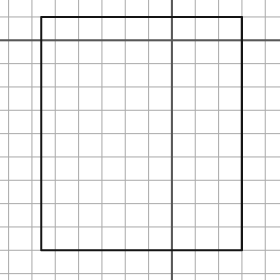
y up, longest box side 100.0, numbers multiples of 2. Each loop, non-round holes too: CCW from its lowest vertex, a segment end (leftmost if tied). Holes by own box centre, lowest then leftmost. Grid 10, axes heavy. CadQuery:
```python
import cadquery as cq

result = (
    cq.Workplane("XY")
    .moveTo(-56.0, -90.0)
    .lineTo(30.0, -90.0)
    .lineTo(30.0, 10.0)
    .lineTo(-56.0, 10.0)
    .close()
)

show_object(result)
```